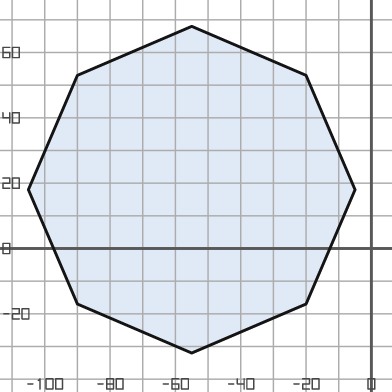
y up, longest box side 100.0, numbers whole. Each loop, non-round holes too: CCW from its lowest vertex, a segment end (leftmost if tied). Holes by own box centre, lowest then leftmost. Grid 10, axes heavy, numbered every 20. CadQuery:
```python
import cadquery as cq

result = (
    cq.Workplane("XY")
    .moveTo(-55.0, -32.0)
    .lineTo(-20.0, -17.0)
    .lineTo(-5.0, 18.0)
    .lineTo(-20.0, 53.0)
    .lineTo(-55.0, 68.0)
    .lineTo(-90.0, 53.0)
    .lineTo(-105.0, 18.0)
    .lineTo(-90.0, -17.0)
    .close()
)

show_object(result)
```